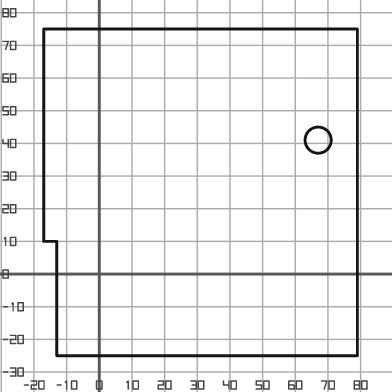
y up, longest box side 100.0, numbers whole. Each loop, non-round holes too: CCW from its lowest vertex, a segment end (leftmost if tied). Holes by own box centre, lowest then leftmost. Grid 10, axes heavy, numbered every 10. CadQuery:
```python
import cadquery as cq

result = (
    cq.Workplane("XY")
    .moveTo(-13.0, -25.0)
    .lineTo(79.0, -25.0)
    .lineTo(79.0, 75.0)
    .lineTo(-17.0, 75.0)
    .lineTo(-17.0, 10.0)
    .lineTo(-13.0, 10.0)
    .close()
    .moveTo(67.0, 41.0)
    .circle(4.0)
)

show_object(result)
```